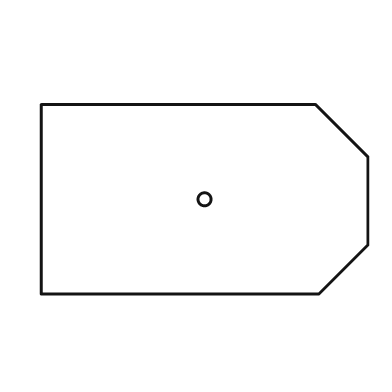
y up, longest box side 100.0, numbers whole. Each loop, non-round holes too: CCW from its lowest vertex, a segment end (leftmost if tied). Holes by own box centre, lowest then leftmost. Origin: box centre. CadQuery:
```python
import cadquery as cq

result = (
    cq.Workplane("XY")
    .moveTo(-50.0, -29.0)
    .lineTo(35.0, -29.0)
    .lineTo(50.0, -14.0)
    .lineTo(50.0, 13.0)
    .lineTo(34.0, 29.0)
    .lineTo(-50.0, 29.0)
    .close()
    .moveTo(0.0, 0.0)
    .circle(2.0)
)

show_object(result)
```